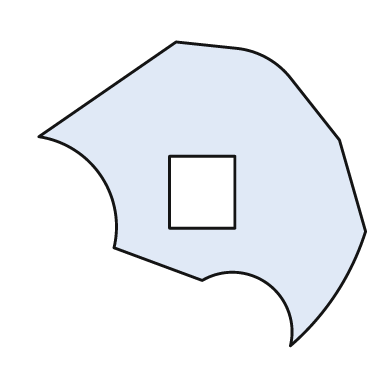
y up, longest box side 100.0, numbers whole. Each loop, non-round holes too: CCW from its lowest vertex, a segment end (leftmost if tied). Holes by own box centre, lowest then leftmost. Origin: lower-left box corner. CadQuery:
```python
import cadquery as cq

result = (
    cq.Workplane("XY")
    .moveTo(77.0, 0.0)
    .threePointArc((91.0, 16.0), (100.0, 35.0))
    .lineTo(92.0, 63.0)
    .lineTo(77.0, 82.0)
    .threePointArc((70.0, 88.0), (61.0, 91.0))
    .lineTo(42.0, 93.0)
    .lineTo(0.0, 64.0)
    .threePointArc((19.0, 52.0), (23.0, 30.0))
    .lineTo(50.0, 20.0)
    .threePointArc((70.0, 19.0), (77.0, 0.0))
    .close()
    .moveTo(40.0, 36.0)
    .lineTo(60.0, 36.0)
    .lineTo(60.0, 58.0)
    .lineTo(40.0, 58.0)
    .close()
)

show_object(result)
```